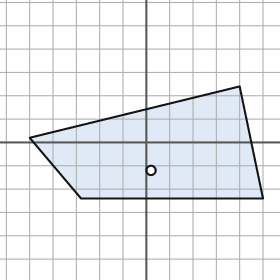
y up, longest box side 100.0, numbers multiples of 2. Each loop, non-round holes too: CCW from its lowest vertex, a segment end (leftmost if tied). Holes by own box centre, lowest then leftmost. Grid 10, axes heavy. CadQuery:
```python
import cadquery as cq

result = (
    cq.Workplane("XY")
    .moveTo(-28.0, -24.0)
    .lineTo(50.0, -24.0)
    .lineTo(40.0, 24.0)
    .lineTo(-50.0, 2.0)
    .close()
    .moveTo(2.0, -12.0)
    .circle(2.0)
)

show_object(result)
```